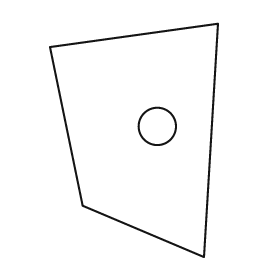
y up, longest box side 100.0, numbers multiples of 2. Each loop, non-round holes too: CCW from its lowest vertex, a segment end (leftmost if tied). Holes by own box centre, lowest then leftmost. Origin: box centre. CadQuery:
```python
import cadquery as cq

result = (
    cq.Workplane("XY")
    .moveTo(30.0, -50.0)
    .lineTo(36.0, 50.0)
    .lineTo(-36.0, 40.0)
    .lineTo(-22.0, -28.0)
    .close()
    .moveTo(10.0, 6.0)
    .circle(8.0)
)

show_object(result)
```